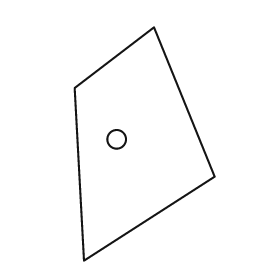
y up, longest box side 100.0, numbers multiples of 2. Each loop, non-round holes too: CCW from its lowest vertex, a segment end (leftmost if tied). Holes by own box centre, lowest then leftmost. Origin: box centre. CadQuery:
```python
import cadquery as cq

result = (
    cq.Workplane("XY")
    .moveTo(-26.0, -50.0)
    .lineTo(30.0, -14.0)
    .lineTo(4.0, 50.0)
    .lineTo(-30.0, 24.0)
    .close()
    .moveTo(-12.0, 2.0)
    .circle(4.0)
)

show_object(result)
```